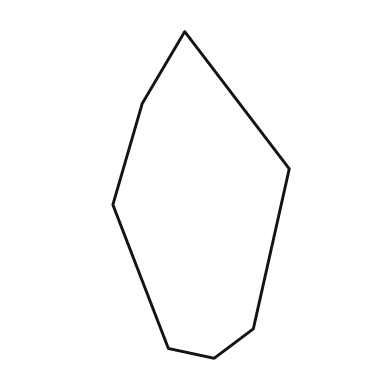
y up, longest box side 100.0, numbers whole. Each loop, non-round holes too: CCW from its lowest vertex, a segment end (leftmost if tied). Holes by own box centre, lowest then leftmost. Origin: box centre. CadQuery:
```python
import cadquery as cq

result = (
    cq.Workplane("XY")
    .moveTo(4.0, -50.0)
    .lineTo(16.0, -41.0)
    .lineTo(27.0, 8.0)
    .lineTo(-5.0, 50.0)
    .lineTo(-18.0, 28.0)
    .lineTo(-27.0, -3.0)
    .lineTo(-10.0, -47.0)
    .close()
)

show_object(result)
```